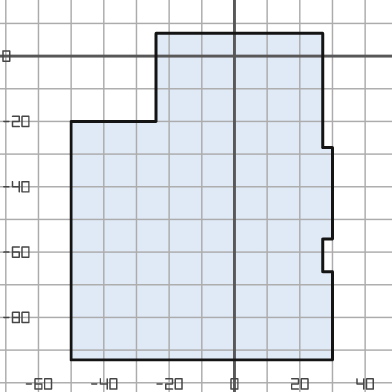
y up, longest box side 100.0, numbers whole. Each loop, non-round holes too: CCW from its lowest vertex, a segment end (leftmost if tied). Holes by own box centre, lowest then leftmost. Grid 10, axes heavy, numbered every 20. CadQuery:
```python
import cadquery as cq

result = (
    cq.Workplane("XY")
    .moveTo(-50.0, -93.0)
    .lineTo(30.0, -93.0)
    .lineTo(30.0, -66.0)
    .lineTo(27.0, -66.0)
    .lineTo(27.0, -56.0)
    .lineTo(30.0, -56.0)
    .lineTo(30.0, -28.0)
    .lineTo(27.0, -28.0)
    .lineTo(27.0, 7.0)
    .lineTo(-24.0, 7.0)
    .lineTo(-24.0, -20.0)
    .lineTo(-50.0, -20.0)
    .close()
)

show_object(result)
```